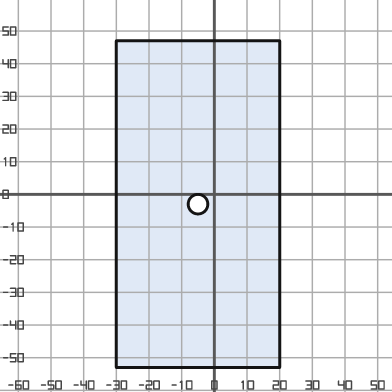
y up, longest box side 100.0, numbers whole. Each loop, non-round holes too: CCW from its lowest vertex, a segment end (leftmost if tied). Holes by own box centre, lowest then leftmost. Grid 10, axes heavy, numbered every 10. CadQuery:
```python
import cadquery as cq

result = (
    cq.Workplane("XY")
    .moveTo(-30.0, -53.0)
    .lineTo(20.0, -53.0)
    .lineTo(20.0, 47.0)
    .lineTo(-30.0, 47.0)
    .close()
    .moveTo(-5.0, -3.0)
    .circle(3.0)
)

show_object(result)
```